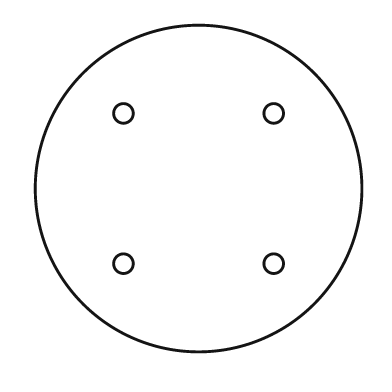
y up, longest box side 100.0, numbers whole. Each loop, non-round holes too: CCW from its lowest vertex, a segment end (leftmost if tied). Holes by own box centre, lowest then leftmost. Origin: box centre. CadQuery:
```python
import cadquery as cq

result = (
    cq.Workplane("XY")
    .moveTo(0.0, 0.0)
    .circle(50.0)
    .moveTo(-23.0, -23.0)
    .circle(3.0)
    .moveTo(23.0, -23.0)
    .circle(3.0)
    .moveTo(-23.0, 23.0)
    .circle(3.0)
    .moveTo(23.0, 23.0)
    .circle(3.0)
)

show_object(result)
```